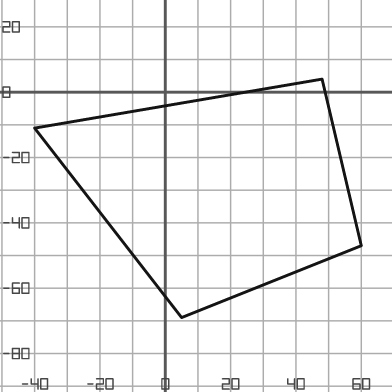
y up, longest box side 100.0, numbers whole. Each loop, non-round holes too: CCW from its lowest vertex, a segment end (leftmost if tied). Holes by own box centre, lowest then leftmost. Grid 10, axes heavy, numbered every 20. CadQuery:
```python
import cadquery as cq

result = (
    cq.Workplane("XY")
    .moveTo(5.0, -69.0)
    .lineTo(60.0, -47.0)
    .lineTo(48.0, 4.0)
    .lineTo(-40.0, -11.0)
    .close()
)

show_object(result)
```